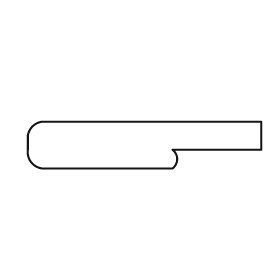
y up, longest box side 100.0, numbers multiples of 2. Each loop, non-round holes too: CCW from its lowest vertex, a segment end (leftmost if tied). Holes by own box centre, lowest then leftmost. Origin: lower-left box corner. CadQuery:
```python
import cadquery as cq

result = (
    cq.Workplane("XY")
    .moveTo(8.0, 0.0)
    .lineTo(62.0, 0.0)
    .threePointArc((64.0, 4.0), (62.0, 8.0))
    .lineTo(100.0, 8.0)
    .lineTo(100.0, 20.0)
    .lineTo(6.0, 20.0)
    .threePointArc((2.0, 18.0), (0.0, 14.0))
    .lineTo(0.0, 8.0)
    .threePointArc((2.0, 2.0), (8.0, 0.0))
    .close()
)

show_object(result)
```